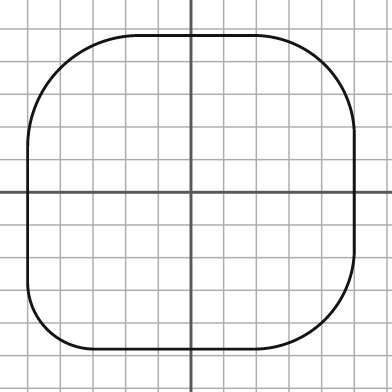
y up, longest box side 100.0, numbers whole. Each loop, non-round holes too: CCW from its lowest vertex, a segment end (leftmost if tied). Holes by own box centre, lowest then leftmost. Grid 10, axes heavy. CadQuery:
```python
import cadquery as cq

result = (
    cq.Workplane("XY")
    .moveTo(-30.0, -48.0)
    .lineTo(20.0, -48.0)
    .threePointArc((41.0, -39.0), (50.0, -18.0))
    .lineTo(50.0, 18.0)
    .threePointArc((41.0, 39.0), (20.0, 48.0))
    .lineTo(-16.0, 48.0)
    .threePointArc((-40.0, 38.0), (-50.0, 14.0))
    .lineTo(-50.0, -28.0)
    .threePointArc((-44.0, -42.0), (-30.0, -48.0))
    .close()
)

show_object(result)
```